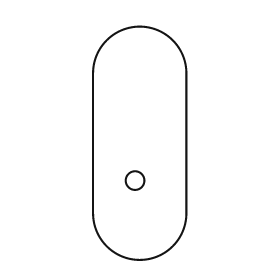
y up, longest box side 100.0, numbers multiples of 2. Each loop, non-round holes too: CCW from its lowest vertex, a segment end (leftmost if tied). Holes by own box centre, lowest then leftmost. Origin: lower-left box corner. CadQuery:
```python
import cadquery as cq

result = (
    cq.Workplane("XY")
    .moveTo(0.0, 20.0)
    .threePointArc((20.0, 0.0), (40.0, 20.0))
    .lineTo(40.0, 80.0)
    .threePointArc((20.0, 100.0), (0.0, 80.0))
    .close()
    .moveTo(18.0, 34.0)
    .circle(4.0)
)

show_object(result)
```